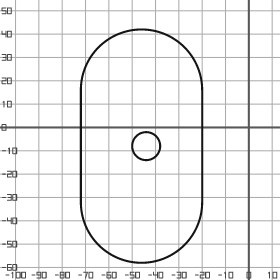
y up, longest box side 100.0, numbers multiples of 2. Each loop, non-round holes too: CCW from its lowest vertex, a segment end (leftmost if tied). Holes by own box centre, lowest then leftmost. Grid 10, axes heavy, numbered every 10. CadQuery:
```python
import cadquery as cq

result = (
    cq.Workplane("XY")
    .moveTo(-72.0, -32.0)
    .threePointArc((-46.0, -58.0), (-20.0, -32.0))
    .lineTo(-20.0, 16.0)
    .threePointArc((-46.0, 42.0), (-72.0, 16.0))
    .close()
    .moveTo(-44.0, -8.0)
    .circle(6.0)
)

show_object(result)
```